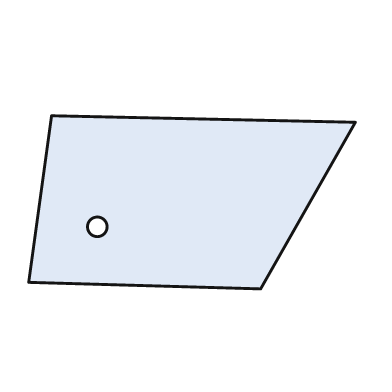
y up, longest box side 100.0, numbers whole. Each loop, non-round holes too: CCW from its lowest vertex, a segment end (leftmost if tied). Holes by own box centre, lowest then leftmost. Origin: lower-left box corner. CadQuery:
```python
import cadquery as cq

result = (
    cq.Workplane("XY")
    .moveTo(71.0, 0.0)
    .lineTo(100.0, 51.0)
    .lineTo(7.0, 53.0)
    .lineTo(0.0, 2.0)
    .close()
    .moveTo(21.0, 19.0)
    .circle(3.0)
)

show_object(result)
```